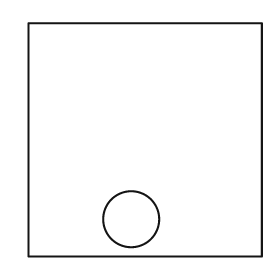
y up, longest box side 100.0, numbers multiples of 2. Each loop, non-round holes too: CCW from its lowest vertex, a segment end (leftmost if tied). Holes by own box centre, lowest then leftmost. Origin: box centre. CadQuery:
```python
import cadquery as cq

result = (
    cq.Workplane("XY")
    .moveTo(-50.0, -50.0)
    .lineTo(50.0, -50.0)
    .lineTo(50.0, 50.0)
    .lineTo(-50.0, 50.0)
    .close()
    .moveTo(-6.0, -34.0)
    .circle(12.0)
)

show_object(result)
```